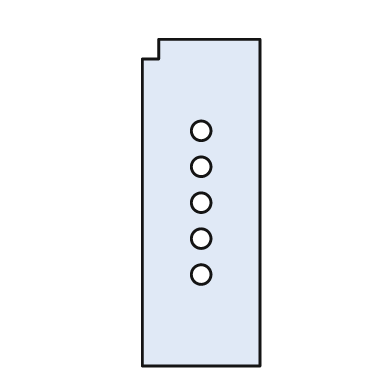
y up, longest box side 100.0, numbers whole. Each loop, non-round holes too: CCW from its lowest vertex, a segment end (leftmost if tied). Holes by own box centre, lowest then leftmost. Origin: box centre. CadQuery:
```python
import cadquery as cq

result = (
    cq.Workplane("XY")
    .moveTo(-18.0, -50.0)
    .lineTo(18.0, -50.0)
    .lineTo(18.0, 50.0)
    .lineTo(-13.0, 50.0)
    .lineTo(-13.0, 44.0)
    .lineTo(-18.0, 44.0)
    .close()
    .moveTo(0.0, -22.0)
    .circle(3.0)
    .moveTo(0.0, -11.0)
    .circle(3.0)
    .moveTo(0.0, 0.0)
    .circle(3.0)
    .moveTo(0.0, 11.0)
    .circle(3.0)
    .moveTo(0.0, 22.0)
    .circle(3.0)
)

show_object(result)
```